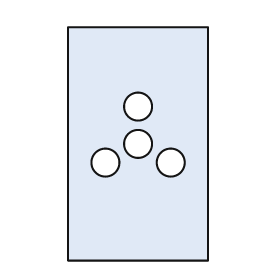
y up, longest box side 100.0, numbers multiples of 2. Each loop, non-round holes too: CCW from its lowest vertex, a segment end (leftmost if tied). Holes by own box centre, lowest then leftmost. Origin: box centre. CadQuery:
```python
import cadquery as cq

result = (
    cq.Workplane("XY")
    .moveTo(-30.0, -50.0)
    .lineTo(30.0, -50.0)
    .lineTo(30.0, 50.0)
    .lineTo(-30.0, 50.0)
    .close()
    .moveTo(-14.0, -8.0)
    .circle(6.0)
    .moveTo(14.0, -8.0)
    .circle(6.0)
    .moveTo(0.0, 0.0)
    .circle(6.0)
    .moveTo(0.0, 16.0)
    .circle(6.0)
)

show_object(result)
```